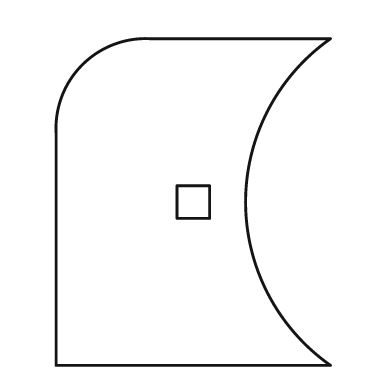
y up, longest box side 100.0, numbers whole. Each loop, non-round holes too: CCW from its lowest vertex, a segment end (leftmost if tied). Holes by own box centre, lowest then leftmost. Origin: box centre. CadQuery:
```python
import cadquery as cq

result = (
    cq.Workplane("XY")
    .moveTo(-42.0, -50.0)
    .lineTo(42.0, -50.0)
    .threePointArc((16.0, 0.0), (42.0, 50.0))
    .lineTo(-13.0, 50.0)
    .threePointArc((-34.0, 42.0), (-42.0, 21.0))
    .close()
    .moveTo(-5.0, -5.0)
    .lineTo(5.0, -5.0)
    .lineTo(5.0, 5.0)
    .lineTo(-5.0, 5.0)
    .close()
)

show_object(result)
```